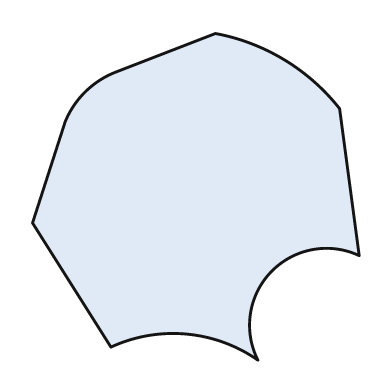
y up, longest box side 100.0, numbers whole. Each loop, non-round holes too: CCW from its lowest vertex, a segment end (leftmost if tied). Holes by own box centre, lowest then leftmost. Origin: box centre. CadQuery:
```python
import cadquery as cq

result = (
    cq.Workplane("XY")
    .moveTo(19.0, -50.0)
    .threePointArc((23.0, -23.0), (50.0, -18.0))
    .lineTo(44.0, 27.0)
    .threePointArc((27.0, 42.0), (6.0, 50.0))
    .lineTo(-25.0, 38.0)
    .threePointArc((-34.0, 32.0), (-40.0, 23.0))
    .lineTo(-50.0, -8.0)
    .lineTo(-26.0, -46.0)
    .threePointArc((-3.0, -42.0), (19.0, -50.0))
    .close()
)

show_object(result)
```